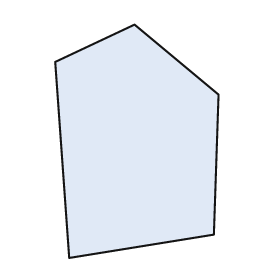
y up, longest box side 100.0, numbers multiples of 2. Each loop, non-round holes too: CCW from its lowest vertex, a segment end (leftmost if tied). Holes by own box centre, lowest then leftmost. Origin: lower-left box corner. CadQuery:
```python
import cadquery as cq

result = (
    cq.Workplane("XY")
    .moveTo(6.0, 0.0)
    .lineTo(68.0, 10.0)
    .lineTo(70.0, 70.0)
    .lineTo(34.0, 100.0)
    .lineTo(0.0, 84.0)
    .close()
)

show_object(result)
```